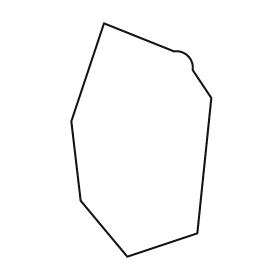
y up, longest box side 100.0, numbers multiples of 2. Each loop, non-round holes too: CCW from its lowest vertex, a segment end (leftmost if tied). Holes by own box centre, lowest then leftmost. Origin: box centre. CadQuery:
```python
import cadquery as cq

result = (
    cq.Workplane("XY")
    .moveTo(-6.0, -50.0)
    .lineTo(24.0, -40.0)
    .lineTo(30.0, 18.0)
    .lineTo(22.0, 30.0)
    .threePointArc((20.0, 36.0), (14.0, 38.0))
    .lineTo(-16.0, 50.0)
    .lineTo(-30.0, 8.0)
    .lineTo(-26.0, -26.0)
    .close()
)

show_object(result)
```